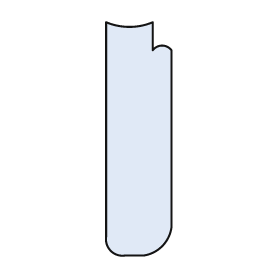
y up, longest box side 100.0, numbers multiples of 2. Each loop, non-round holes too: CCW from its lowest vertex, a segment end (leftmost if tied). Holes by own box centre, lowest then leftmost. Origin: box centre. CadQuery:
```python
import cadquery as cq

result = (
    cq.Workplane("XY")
    .moveTo(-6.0, -50.0)
    .lineTo(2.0, -50.0)
    .threePointArc((10.0, -46.0), (14.0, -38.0))
    .lineTo(14.0, 38.0)
    .threePointArc((10.0, 40.0), (6.0, 38.0))
    .lineTo(6.0, 50.0)
    .threePointArc((-4.0, 48.0), (-14.0, 50.0))
    .lineTo(-14.0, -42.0)
    .threePointArc((-12.0, -48.0), (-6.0, -50.0))
    .close()
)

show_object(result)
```